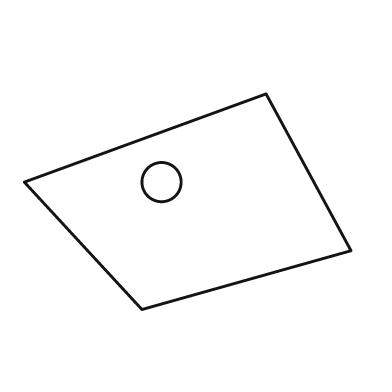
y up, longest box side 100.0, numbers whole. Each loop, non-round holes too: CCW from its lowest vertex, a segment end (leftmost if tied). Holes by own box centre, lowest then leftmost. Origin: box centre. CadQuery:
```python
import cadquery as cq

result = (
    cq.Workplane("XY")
    .moveTo(-14.0, -33.0)
    .lineTo(50.0, -15.0)
    .lineTo(24.0, 33.0)
    .lineTo(-50.0, 6.0)
    .close()
    .moveTo(-8.0, 6.0)
    .circle(6.0)
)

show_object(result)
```